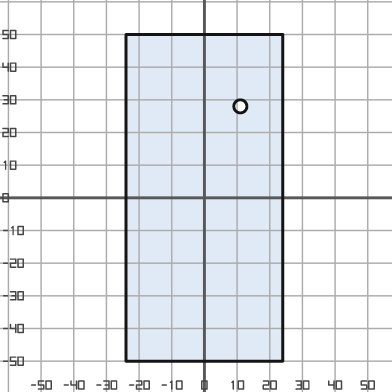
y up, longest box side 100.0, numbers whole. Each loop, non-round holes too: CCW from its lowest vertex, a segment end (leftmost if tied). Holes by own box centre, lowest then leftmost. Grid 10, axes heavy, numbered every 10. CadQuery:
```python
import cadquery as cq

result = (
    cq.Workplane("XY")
    .moveTo(-24.0, -50.0)
    .lineTo(24.0, -50.0)
    .lineTo(24.0, 50.0)
    .lineTo(-24.0, 50.0)
    .close()
    .moveTo(11.0, 28.0)
    .circle(2.0)
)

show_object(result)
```